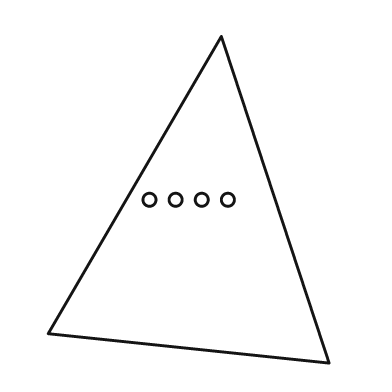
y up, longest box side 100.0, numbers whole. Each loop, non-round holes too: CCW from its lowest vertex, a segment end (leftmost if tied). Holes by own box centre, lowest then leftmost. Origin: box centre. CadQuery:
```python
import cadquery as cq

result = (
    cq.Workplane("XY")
    .moveTo(43.0, -50.0)
    .lineTo(10.0, 50.0)
    .lineTo(-43.0, -41.0)
    .close()
    .moveTo(-12.0, 0.0)
    .circle(2.0)
    .moveTo(-4.0, 0.0)
    .circle(2.0)
    .moveTo(4.0, 0.0)
    .circle(2.0)
    .moveTo(12.0, 0.0)
    .circle(2.0)
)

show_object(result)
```